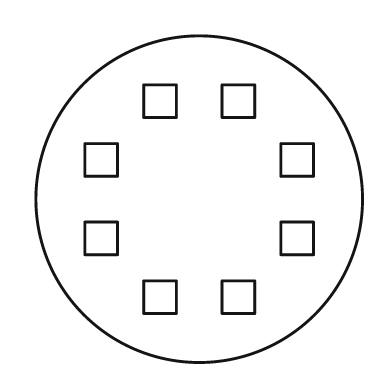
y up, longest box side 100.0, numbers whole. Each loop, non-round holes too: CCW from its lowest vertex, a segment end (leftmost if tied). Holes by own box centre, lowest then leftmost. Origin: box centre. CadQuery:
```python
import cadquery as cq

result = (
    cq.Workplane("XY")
    .moveTo(0.0, 0.0)
    .circle(50.0)
    .moveTo(-17.0, -35.0)
    .lineTo(-7.0, -35.0)
    .lineTo(-7.0, -25.0)
    .lineTo(-17.0, -25.0)
    .close()
    .moveTo(7.0, -35.0)
    .lineTo(17.0, -35.0)
    .lineTo(17.0, -25.0)
    .lineTo(7.0, -25.0)
    .close()
    .moveTo(-35.0, -17.0)
    .lineTo(-25.0, -17.0)
    .lineTo(-25.0, -7.0)
    .lineTo(-35.0, -7.0)
    .close()
    .moveTo(25.0, -17.0)
    .lineTo(35.0, -17.0)
    .lineTo(35.0, -7.0)
    .lineTo(25.0, -7.0)
    .close()
    .moveTo(-35.0, 7.0)
    .lineTo(-25.0, 7.0)
    .lineTo(-25.0, 17.0)
    .lineTo(-35.0, 17.0)
    .close()
    .moveTo(25.0, 7.0)
    .lineTo(35.0, 7.0)
    .lineTo(35.0, 17.0)
    .lineTo(25.0, 17.0)
    .close()
    .moveTo(-17.0, 25.0)
    .lineTo(-7.0, 25.0)
    .lineTo(-7.0, 35.0)
    .lineTo(-17.0, 35.0)
    .close()
    .moveTo(7.0, 25.0)
    .lineTo(17.0, 25.0)
    .lineTo(17.0, 35.0)
    .lineTo(7.0, 35.0)
    .close()
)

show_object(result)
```